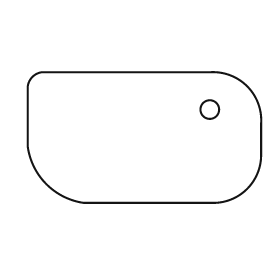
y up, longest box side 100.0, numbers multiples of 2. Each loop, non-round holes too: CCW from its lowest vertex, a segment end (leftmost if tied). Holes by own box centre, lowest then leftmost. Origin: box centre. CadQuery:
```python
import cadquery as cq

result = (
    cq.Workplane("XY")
    .moveTo(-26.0, -28.0)
    .lineTo(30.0, -28.0)
    .threePointArc((44.0, -22.0), (50.0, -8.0))
    .lineTo(50.0, 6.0)
    .threePointArc((44.0, 22.0), (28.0, 28.0))
    .lineTo(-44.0, 28.0)
    .threePointArc((-48.0, 26.0), (-50.0, 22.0))
    .lineTo(-50.0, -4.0)
    .threePointArc((-42.0, -20.0), (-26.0, -28.0))
    .close()
    .moveTo(28.0, 12.0)
    .circle(4.0)
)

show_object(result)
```